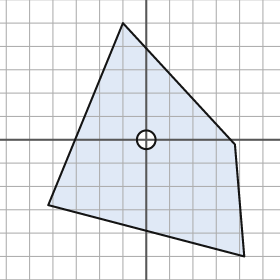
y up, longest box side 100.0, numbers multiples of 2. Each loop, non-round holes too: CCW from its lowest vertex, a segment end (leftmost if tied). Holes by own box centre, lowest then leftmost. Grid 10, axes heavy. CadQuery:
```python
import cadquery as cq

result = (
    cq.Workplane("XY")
    .moveTo(42.0, -50.0)
    .lineTo(38.0, -2.0)
    .lineTo(-10.0, 50.0)
    .lineTo(-42.0, -28.0)
    .close()
    .moveTo(0.0, 0.0)
    .circle(4.0)
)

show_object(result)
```